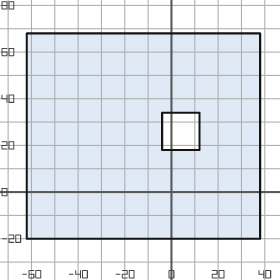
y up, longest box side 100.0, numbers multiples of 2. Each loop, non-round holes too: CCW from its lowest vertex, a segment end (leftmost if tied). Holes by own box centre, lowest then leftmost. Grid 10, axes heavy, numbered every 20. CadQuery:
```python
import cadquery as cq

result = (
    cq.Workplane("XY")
    .moveTo(-62.0, -20.0)
    .lineTo(38.0, -20.0)
    .lineTo(38.0, 68.0)
    .lineTo(-62.0, 68.0)
    .close()
    .moveTo(-4.0, 18.0)
    .lineTo(12.0, 18.0)
    .lineTo(12.0, 34.0)
    .lineTo(-4.0, 34.0)
    .close()
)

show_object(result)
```